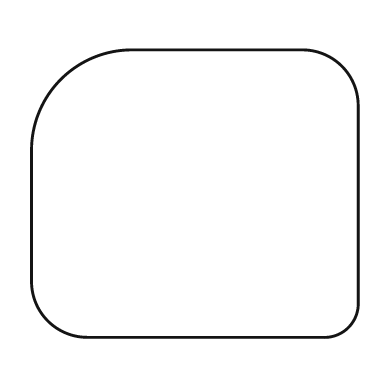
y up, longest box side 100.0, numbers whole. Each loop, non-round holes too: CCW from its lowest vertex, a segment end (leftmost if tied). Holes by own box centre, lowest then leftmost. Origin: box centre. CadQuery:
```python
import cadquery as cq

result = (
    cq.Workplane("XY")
    .moveTo(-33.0, -44.0)
    .lineTo(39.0, -44.0)
    .threePointArc((47.0, -41.0), (50.0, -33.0))
    .lineTo(50.0, 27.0)
    .threePointArc((45.0, 39.0), (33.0, 44.0))
    .lineTo(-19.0, 44.0)
    .threePointArc((-41.0, 35.0), (-50.0, 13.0))
    .lineTo(-50.0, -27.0)
    .threePointArc((-45.0, -39.0), (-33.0, -44.0))
    .close()
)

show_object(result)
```